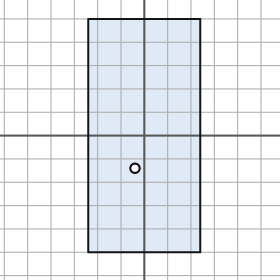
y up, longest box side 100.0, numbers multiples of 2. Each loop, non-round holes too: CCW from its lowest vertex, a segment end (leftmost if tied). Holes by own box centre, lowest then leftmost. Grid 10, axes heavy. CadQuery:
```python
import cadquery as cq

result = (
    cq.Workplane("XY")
    .moveTo(-24.0, -50.0)
    .lineTo(24.0, -50.0)
    .lineTo(24.0, 50.0)
    .lineTo(-24.0, 50.0)
    .close()
    .moveTo(-4.0, -14.0)
    .circle(2.0)
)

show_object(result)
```